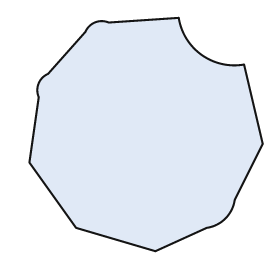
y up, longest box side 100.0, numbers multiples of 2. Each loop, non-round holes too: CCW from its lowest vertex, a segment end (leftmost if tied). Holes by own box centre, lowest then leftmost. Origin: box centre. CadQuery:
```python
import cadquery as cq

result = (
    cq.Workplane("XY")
    .moveTo(4.0, -50.0)
    .lineTo(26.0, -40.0)
    .threePointArc((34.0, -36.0), (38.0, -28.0))
    .lineTo(50.0, -4.0)
    .lineTo(42.0, 30.0)
    .threePointArc((24.0, 34.0), (14.0, 50.0))
    .lineTo(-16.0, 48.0)
    .threePointArc((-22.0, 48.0), (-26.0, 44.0))
    .lineTo(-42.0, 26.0)
    .threePointArc((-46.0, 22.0), (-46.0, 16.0))
    .lineTo(-50.0, -12.0)
    .lineTo(-30.0, -40.0)
    .close()
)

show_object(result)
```